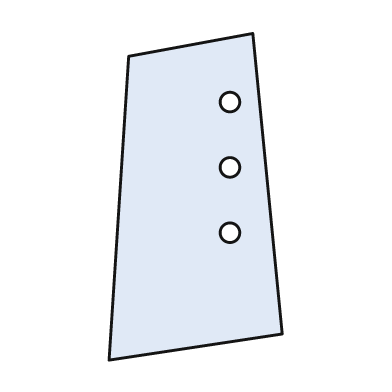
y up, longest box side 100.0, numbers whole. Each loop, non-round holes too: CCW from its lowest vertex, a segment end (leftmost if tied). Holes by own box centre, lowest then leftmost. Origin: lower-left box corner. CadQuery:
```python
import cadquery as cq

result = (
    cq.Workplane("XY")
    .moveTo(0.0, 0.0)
    .lineTo(53.0, 8.0)
    .lineTo(44.0, 100.0)
    .lineTo(6.0, 93.0)
    .close()
    .moveTo(37.0, 39.0)
    .circle(3.0)
    .moveTo(37.0, 59.0)
    .circle(3.0)
    .moveTo(37.0, 79.0)
    .circle(3.0)
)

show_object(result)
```